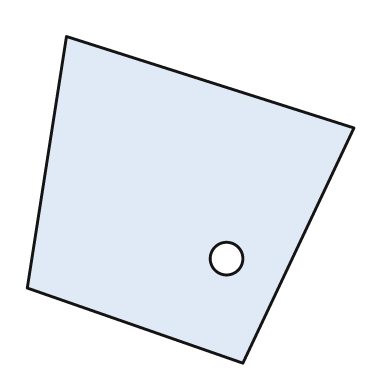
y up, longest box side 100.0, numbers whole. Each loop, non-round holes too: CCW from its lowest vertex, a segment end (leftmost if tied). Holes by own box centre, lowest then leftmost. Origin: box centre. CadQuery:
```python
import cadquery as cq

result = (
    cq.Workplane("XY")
    .moveTo(16.0, -50.0)
    .lineTo(50.0, 22.0)
    .lineTo(-38.0, 50.0)
    .lineTo(-50.0, -27.0)
    .close()
    .moveTo(11.0, -18.0)
    .circle(5.0)
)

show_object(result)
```